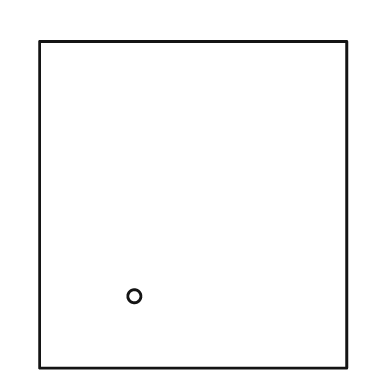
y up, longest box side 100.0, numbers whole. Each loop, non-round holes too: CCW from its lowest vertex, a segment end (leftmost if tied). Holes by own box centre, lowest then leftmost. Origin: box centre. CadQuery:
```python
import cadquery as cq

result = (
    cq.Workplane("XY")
    .moveTo(-47.0, -50.0)
    .lineTo(47.0, -50.0)
    .lineTo(47.0, 50.0)
    .lineTo(-47.0, 50.0)
    .close()
    .moveTo(-18.0, -28.0)
    .circle(2.0)
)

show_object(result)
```